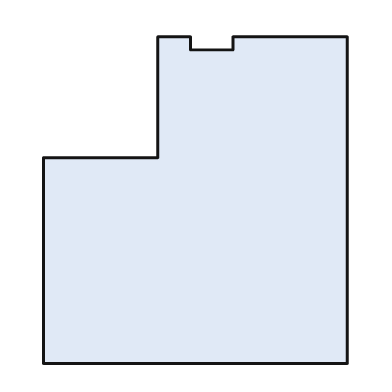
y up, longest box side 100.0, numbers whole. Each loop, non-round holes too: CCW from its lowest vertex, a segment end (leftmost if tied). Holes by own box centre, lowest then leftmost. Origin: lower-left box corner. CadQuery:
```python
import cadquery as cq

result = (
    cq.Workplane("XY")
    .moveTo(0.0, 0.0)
    .lineTo(93.0, 0.0)
    .lineTo(93.0, 100.0)
    .lineTo(58.0, 100.0)
    .lineTo(58.0, 96.0)
    .lineTo(45.0, 96.0)
    .lineTo(45.0, 100.0)
    .lineTo(35.0, 100.0)
    .lineTo(35.0, 63.0)
    .lineTo(0.0, 63.0)
    .close()
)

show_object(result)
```